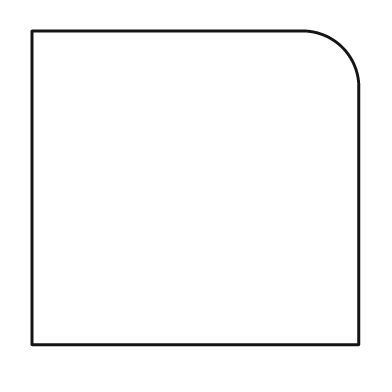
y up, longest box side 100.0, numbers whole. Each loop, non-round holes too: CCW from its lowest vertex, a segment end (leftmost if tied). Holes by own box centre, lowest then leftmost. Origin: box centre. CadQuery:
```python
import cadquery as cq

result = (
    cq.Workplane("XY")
    .moveTo(-50.0, -48.0)
    .lineTo(50.0, -48.0)
    .lineTo(50.0, 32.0)
    .threePointArc((45.0, 43.0), (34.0, 48.0))
    .lineTo(-50.0, 48.0)
    .close()
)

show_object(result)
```